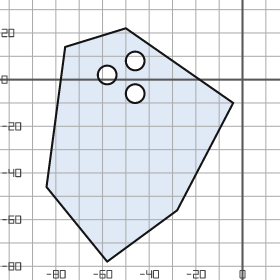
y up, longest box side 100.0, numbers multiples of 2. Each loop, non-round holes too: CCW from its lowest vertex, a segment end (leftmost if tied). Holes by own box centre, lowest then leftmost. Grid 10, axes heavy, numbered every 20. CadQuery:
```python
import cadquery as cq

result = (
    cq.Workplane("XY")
    .moveTo(-58.0, -78.0)
    .lineTo(-28.0, -56.0)
    .lineTo(-4.0, -10.0)
    .lineTo(-50.0, 22.0)
    .lineTo(-76.0, 14.0)
    .lineTo(-84.0, -46.0)
    .close()
    .moveTo(-46.0, -6.0)
    .circle(4.0)
    .moveTo(-58.0, 2.0)
    .circle(4.0)
    .moveTo(-46.0, 8.0)
    .circle(4.0)
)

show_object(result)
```